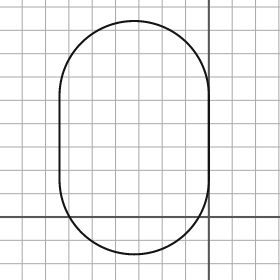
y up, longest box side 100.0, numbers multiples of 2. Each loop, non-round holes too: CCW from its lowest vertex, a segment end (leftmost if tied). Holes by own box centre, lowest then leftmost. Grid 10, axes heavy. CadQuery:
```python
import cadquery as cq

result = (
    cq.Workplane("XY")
    .moveTo(-64.0, 16.0)
    .threePointArc((-32.0, -16.0), (0.0, 16.0))
    .lineTo(0.0, 52.0)
    .threePointArc((-32.0, 84.0), (-64.0, 52.0))
    .close()
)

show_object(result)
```